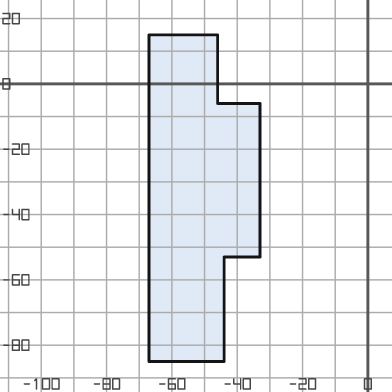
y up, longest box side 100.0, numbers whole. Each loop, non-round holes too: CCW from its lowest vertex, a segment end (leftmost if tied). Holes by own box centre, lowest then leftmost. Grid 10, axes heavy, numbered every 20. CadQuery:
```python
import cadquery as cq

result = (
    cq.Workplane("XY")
    .moveTo(-67.0, -85.0)
    .lineTo(-44.0, -85.0)
    .lineTo(-44.0, -53.0)
    .lineTo(-33.0, -53.0)
    .lineTo(-33.0, -6.0)
    .lineTo(-46.0, -6.0)
    .lineTo(-46.0, 15.0)
    .lineTo(-67.0, 15.0)
    .close()
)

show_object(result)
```